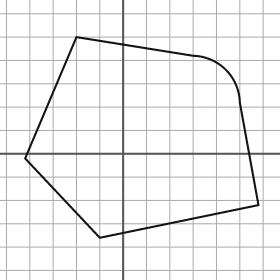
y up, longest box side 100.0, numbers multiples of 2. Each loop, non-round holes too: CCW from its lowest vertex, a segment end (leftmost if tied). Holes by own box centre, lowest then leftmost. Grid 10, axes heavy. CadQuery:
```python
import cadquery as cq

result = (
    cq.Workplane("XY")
    .moveTo(-10.0, -36.0)
    .lineTo(58.0, -22.0)
    .lineTo(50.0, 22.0)
    .threePointArc((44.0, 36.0), (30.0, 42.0))
    .lineTo(-20.0, 50.0)
    .lineTo(-42.0, -2.0)
    .close()
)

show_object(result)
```